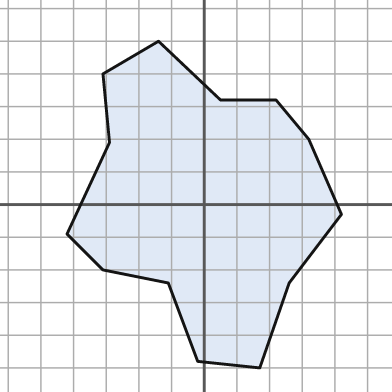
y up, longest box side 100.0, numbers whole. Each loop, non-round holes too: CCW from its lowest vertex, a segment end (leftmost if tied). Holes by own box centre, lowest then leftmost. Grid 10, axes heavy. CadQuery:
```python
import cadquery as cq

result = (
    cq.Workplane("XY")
    .moveTo(17.0, -50.0)
    .lineTo(26.0, -24.0)
    .lineTo(42.0, -3.0)
    .lineTo(32.0, 20.0)
    .lineTo(22.0, 32.0)
    .lineTo(5.0, 32.0)
    .lineTo(-14.0, 50.0)
    .lineTo(-31.0, 40.0)
    .lineTo(-29.0, 19.0)
    .lineTo(-42.0, -9.0)
    .lineTo(-31.0, -20.0)
    .lineTo(-11.0, -24.0)
    .lineTo(-2.0, -48.0)
    .close()
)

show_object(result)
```